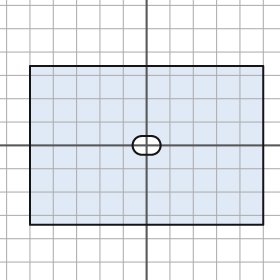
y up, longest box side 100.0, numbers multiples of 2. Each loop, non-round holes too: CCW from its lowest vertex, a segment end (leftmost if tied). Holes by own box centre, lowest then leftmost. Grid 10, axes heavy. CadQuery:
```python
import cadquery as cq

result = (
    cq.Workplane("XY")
    .moveTo(-50.0, -34.0)
    .lineTo(50.0, -34.0)
    .lineTo(50.0, 34.0)
    .lineTo(-50.0, 34.0)
    .close()
    .moveTo(-2.0, -4.0)
    .lineTo(2.0, -4.0)
    .threePointArc((6.0, 0.0), (2.0, 4.0))
    .lineTo(-2.0, 4.0)
    .threePointArc((-6.0, 0.0), (-2.0, -4.0))
    .close()
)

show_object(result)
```